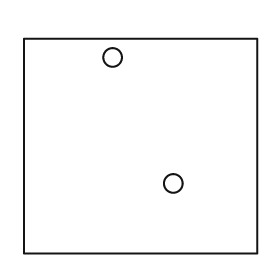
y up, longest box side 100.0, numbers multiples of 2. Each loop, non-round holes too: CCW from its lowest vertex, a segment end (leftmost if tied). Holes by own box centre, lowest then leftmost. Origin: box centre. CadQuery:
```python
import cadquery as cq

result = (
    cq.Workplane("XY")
    .moveTo(-50.0, -46.0)
    .lineTo(50.0, -46.0)
    .lineTo(50.0, 46.0)
    .lineTo(-50.0, 46.0)
    .close()
    .moveTo(14.0, -16.0)
    .circle(4.0)
    .moveTo(-12.0, 38.0)
    .circle(4.0)
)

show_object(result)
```